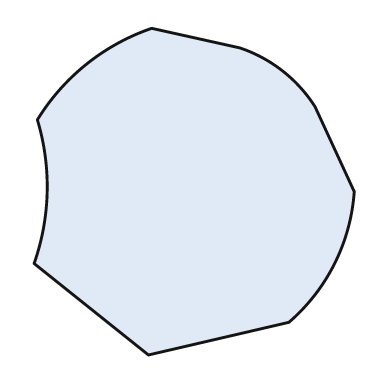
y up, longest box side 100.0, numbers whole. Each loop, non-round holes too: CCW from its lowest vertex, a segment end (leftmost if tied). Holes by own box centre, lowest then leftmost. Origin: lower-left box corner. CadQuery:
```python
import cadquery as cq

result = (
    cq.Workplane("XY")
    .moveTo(35.0, 0.0)
    .lineTo(78.0, 10.0)
    .threePointArc((92.0, 28.0), (98.0, 50.0))
    .lineTo(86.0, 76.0)
    .threePointArc((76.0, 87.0), (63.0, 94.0))
    .lineTo(36.0, 100.0)
    .threePointArc((16.0, 89.0), (1.0, 72.0))
    .threePointArc((4.0, 50.0), (0.0, 28.0))
    .close()
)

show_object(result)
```